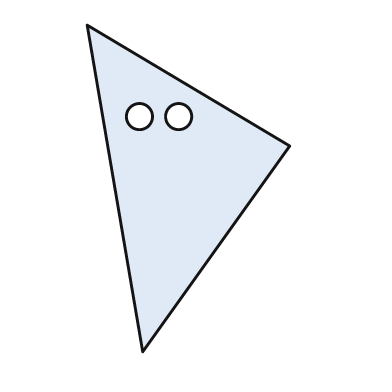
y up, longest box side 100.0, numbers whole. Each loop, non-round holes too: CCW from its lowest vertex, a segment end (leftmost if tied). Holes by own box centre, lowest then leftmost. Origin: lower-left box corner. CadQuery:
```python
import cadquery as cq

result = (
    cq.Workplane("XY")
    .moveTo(17.0, 0.0)
    .lineTo(62.0, 63.0)
    .lineTo(0.0, 100.0)
    .close()
    .moveTo(16.0, 72.0)
    .circle(4.0)
    .moveTo(28.0, 72.0)
    .circle(4.0)
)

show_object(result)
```